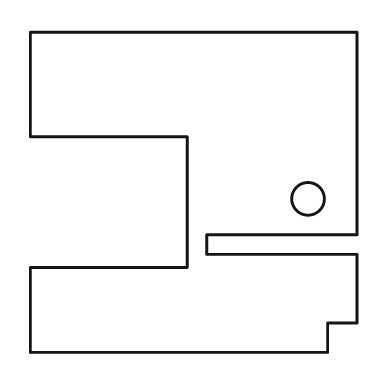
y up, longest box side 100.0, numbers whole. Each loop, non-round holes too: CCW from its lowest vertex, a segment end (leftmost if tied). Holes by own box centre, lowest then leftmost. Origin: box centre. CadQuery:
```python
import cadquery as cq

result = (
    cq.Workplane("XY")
    .moveTo(-50.0, -49.0)
    .lineTo(41.0, -49.0)
    .lineTo(41.0, -40.0)
    .lineTo(50.0, -40.0)
    .lineTo(50.0, -19.0)
    .lineTo(4.0, -19.0)
    .lineTo(4.0, -13.0)
    .lineTo(50.0, -13.0)
    .lineTo(50.0, 49.0)
    .lineTo(-50.0, 49.0)
    .lineTo(-50.0, 17.0)
    .lineTo(-2.0, 17.0)
    .lineTo(-2.0, -23.0)
    .lineTo(-50.0, -23.0)
    .close()
    .moveTo(35.0, -2.0)
    .circle(5.0)
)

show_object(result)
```